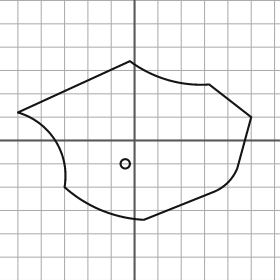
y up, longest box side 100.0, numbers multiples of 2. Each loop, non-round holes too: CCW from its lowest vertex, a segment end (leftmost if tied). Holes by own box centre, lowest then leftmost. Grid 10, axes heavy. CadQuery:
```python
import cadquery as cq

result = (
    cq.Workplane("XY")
    .moveTo(4.0, -34.0)
    .lineTo(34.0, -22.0)
    .threePointArc((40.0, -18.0), (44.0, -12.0))
    .lineTo(50.0, 10.0)
    .lineTo(32.0, 24.0)
    .threePointArc((14.0, 26.0), (-2.0, 34.0))
    .lineTo(-50.0, 12.0)
    .threePointArc((-34.0, 0.0), (-30.0, -20.0))
    .threePointArc((-14.0, -30.0), (4.0, -34.0))
    .close()
    .moveTo(-4.0, -10.0)
    .circle(2.0)
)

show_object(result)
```